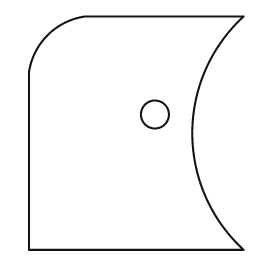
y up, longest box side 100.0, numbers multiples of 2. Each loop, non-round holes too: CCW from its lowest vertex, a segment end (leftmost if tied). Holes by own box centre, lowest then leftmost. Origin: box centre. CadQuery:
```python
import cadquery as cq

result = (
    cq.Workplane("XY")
    .moveTo(-46.0, -50.0)
    .lineTo(46.0, -50.0)
    .threePointArc((24.0, 0.0), (46.0, 50.0))
    .lineTo(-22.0, 50.0)
    .threePointArc((-38.0, 42.0), (-46.0, 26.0))
    .close()
    .moveTo(8.0, 8.0)
    .circle(6.0)
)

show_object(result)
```